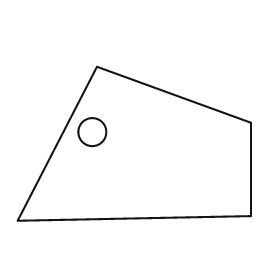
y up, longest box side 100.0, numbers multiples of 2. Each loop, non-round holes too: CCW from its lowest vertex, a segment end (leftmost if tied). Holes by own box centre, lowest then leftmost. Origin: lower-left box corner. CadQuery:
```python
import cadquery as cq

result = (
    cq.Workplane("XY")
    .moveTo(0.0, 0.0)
    .lineTo(100.0, 2.0)
    .lineTo(100.0, 42.0)
    .lineTo(34.0, 66.0)
    .close()
    .moveTo(32.0, 38.0)
    .circle(6.0)
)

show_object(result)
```